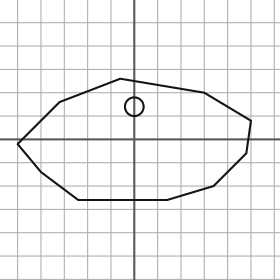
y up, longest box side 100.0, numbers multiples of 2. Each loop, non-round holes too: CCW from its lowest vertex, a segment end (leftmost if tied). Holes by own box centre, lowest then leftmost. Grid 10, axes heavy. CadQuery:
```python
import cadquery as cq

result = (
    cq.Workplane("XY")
    .moveTo(-24.0, -26.0)
    .lineTo(14.0, -26.0)
    .lineTo(34.0, -20.0)
    .lineTo(48.0, -6.0)
    .lineTo(50.0, 8.0)
    .lineTo(30.0, 20.0)
    .lineTo(-6.0, 26.0)
    .lineTo(-32.0, 16.0)
    .lineTo(-50.0, -2.0)
    .lineTo(-40.0, -14.0)
    .close()
    .moveTo(0.0, 14.0)
    .circle(4.0)
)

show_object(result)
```